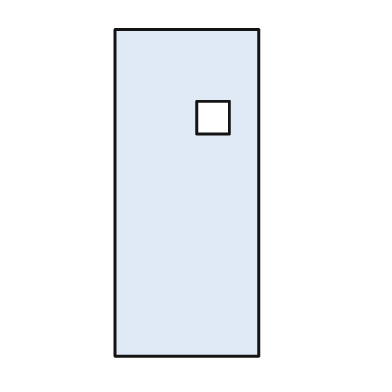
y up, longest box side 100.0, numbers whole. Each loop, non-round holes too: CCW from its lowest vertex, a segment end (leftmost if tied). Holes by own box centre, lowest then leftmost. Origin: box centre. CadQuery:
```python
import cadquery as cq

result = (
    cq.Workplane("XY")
    .moveTo(-22.0, -50.0)
    .lineTo(22.0, -50.0)
    .lineTo(22.0, 50.0)
    .lineTo(-22.0, 50.0)
    .close()
    .moveTo(3.0, 18.0)
    .lineTo(13.0, 18.0)
    .lineTo(13.0, 28.0)
    .lineTo(3.0, 28.0)
    .close()
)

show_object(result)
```